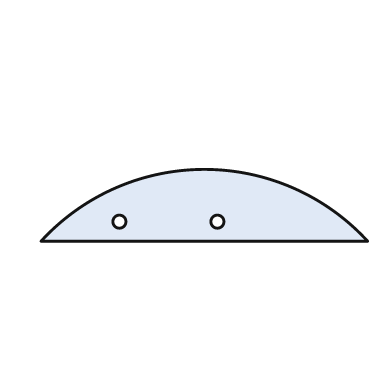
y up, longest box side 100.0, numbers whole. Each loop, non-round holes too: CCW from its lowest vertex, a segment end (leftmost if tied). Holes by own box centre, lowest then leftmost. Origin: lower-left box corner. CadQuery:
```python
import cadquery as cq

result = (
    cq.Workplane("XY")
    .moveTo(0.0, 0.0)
    .lineTo(100.0, 0.0)
    .threePointArc((50.0, 22.0), (0.0, 0.0))
    .close()
    .moveTo(24.0, 6.0)
    .circle(2.0)
    .moveTo(54.0, 6.0)
    .circle(2.0)
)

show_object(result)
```